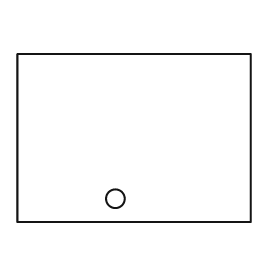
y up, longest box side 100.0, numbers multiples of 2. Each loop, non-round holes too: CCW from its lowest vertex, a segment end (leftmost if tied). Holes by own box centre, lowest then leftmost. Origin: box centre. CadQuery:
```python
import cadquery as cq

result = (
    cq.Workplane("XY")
    .moveTo(-50.0, -36.0)
    .lineTo(50.0, -36.0)
    .lineTo(50.0, 36.0)
    .lineTo(-50.0, 36.0)
    .close()
    .moveTo(-8.0, -26.0)
    .circle(4.0)
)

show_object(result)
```